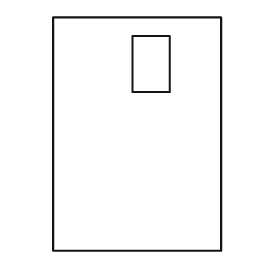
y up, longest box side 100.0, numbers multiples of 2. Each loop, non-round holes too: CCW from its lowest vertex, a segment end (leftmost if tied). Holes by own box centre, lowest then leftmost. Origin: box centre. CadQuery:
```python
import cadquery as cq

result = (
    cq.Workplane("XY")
    .moveTo(-36.0, -50.0)
    .lineTo(36.0, -50.0)
    .lineTo(36.0, 50.0)
    .lineTo(-36.0, 50.0)
    .close()
    .moveTo(-2.0, 18.0)
    .lineTo(14.0, 18.0)
    .lineTo(14.0, 42.0)
    .lineTo(-2.0, 42.0)
    .close()
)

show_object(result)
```